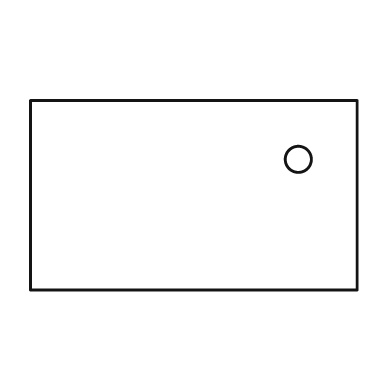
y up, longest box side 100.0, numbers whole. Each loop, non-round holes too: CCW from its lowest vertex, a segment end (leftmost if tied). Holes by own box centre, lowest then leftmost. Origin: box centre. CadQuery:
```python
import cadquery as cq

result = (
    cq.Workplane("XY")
    .moveTo(-50.0, -29.0)
    .lineTo(50.0, -29.0)
    .lineTo(50.0, 29.0)
    .lineTo(-50.0, 29.0)
    .close()
    .moveTo(32.0, 11.0)
    .circle(4.0)
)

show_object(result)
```